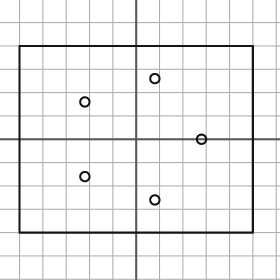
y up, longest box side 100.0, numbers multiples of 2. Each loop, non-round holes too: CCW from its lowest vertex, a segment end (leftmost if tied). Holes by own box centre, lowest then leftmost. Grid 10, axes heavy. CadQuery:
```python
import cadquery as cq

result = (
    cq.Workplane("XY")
    .moveTo(-50.0, -40.0)
    .lineTo(50.0, -40.0)
    .lineTo(50.0, 40.0)
    .lineTo(-50.0, 40.0)
    .close()
    .moveTo(8.0, -26.0)
    .circle(2.0)
    .moveTo(-22.0, -16.0)
    .circle(2.0)
    .moveTo(28.0, 0.0)
    .circle(2.0)
    .moveTo(-22.0, 16.0)
    .circle(2.0)
    .moveTo(8.0, 26.0)
    .circle(2.0)
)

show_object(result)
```